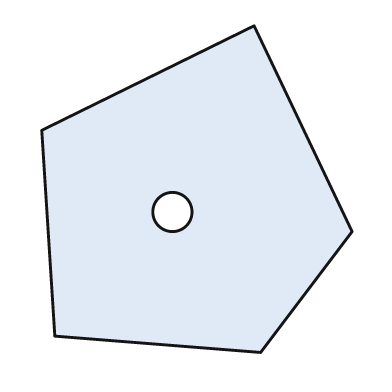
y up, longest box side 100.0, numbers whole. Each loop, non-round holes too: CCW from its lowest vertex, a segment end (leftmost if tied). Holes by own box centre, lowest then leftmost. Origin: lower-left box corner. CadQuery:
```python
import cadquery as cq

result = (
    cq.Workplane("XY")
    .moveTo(67.0, 0.0)
    .lineTo(95.0, 37.0)
    .lineTo(65.0, 100.0)
    .lineTo(0.0, 68.0)
    .lineTo(4.0, 5.0)
    .close()
    .moveTo(40.0, 43.0)
    .circle(6.0)
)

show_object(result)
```